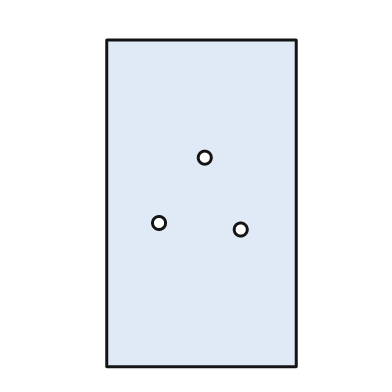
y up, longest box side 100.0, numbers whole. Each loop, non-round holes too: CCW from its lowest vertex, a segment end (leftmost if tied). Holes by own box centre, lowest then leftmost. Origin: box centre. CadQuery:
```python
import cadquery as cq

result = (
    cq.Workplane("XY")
    .moveTo(-29.0, -50.0)
    .lineTo(29.0, -50.0)
    .lineTo(29.0, 50.0)
    .lineTo(-29.0, 50.0)
    .close()
    .moveTo(12.0, -8.0)
    .circle(2.0)
    .moveTo(-13.0, -6.0)
    .circle(2.0)
    .moveTo(1.0, 14.0)
    .circle(2.0)
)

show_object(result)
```